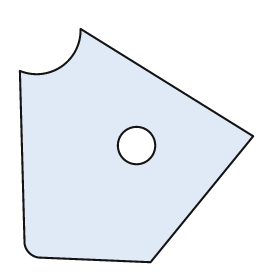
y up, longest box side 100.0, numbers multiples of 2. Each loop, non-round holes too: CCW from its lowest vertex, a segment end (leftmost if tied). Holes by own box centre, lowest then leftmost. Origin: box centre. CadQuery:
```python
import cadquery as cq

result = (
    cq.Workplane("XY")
    .moveTo(6.0, -50.0)
    .lineTo(50.0, 4.0)
    .lineTo(-24.0, 50.0)
    .threePointArc((-32.0, 34.0), (-50.0, 32.0))
    .lineTo(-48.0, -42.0)
    .threePointArc((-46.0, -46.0), (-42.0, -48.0))
    .close()
    .moveTo(0.0, 0.0)
    .circle(8.0)
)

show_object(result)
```